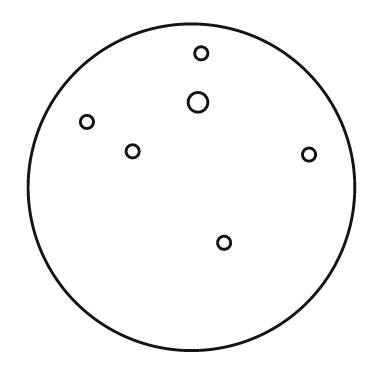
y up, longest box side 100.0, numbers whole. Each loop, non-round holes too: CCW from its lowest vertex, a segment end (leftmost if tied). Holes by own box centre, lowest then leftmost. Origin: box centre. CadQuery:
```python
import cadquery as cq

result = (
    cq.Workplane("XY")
    .moveTo(0.0, 0.0)
    .circle(50.0)
    .moveTo(10.0, -17.0)
    .circle(2.0)
    .moveTo(36.0, 10.0)
    .circle(2.0)
    .moveTo(-18.0, 11.0)
    .circle(2.0)
    .moveTo(-32.0, 20.0)
    .circle(2.0)
    .moveTo(2.0, 26.0)
    .circle(3.0)
    .moveTo(3.0, 41.0)
    .circle(2.0)
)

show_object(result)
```